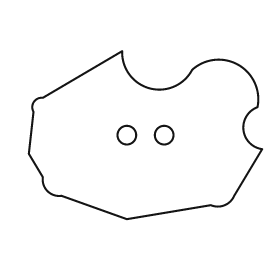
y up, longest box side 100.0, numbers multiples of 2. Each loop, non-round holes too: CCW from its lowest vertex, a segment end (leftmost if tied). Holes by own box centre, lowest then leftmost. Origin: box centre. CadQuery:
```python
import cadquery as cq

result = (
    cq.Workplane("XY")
    .moveTo(-8.0, -36.0)
    .lineTo(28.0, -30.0)
    .threePointArc((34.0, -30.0), (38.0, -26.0))
    .lineTo(50.0, -6.0)
    .threePointArc((42.0, 2.0), (48.0, 12.0))
    .threePointArc((40.0, 30.0), (20.0, 28.0))
    .threePointArc((2.0, 20.0), (-10.0, 36.0))
    .lineTo(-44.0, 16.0)
    .threePointArc((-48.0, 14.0), (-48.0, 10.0))
    .lineTo(-50.0, -8.0)
    .lineTo(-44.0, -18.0)
    .threePointArc((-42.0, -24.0), (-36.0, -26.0))
    .close()
    .moveTo(-8.0, 0.0)
    .circle(4.0)
    .moveTo(8.0, 0.0)
    .circle(4.0)
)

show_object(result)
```